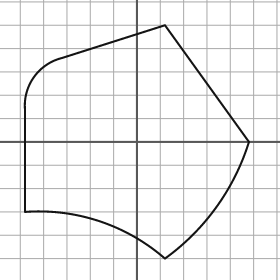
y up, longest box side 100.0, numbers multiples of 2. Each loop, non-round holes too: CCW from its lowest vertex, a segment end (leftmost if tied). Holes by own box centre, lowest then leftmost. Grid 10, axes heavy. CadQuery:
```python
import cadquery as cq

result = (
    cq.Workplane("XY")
    .moveTo(12.0, -50.0)
    .threePointArc((34.0, -28.0), (48.0, 0.0))
    .lineTo(12.0, 50.0)
    .lineTo(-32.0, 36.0)
    .threePointArc((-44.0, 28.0), (-48.0, 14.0))
    .lineTo(-48.0, -30.0)
    .threePointArc((-16.0, -34.0), (12.0, -50.0))
    .close()
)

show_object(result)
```